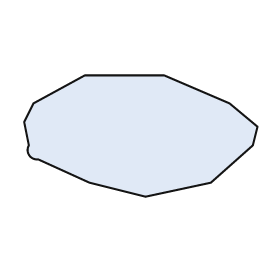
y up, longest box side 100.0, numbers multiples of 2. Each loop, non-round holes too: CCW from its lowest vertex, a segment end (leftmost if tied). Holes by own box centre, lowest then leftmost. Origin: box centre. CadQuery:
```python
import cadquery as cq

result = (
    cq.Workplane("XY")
    .moveTo(2.0, -26.0)
    .lineTo(30.0, -20.0)
    .lineTo(48.0, -4.0)
    .lineTo(50.0, 4.0)
    .lineTo(38.0, 14.0)
    .lineTo(10.0, 26.0)
    .lineTo(-24.0, 26.0)
    .lineTo(-46.0, 14.0)
    .lineTo(-50.0, 6.0)
    .lineTo(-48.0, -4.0)
    .threePointArc((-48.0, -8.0), (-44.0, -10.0))
    .lineTo(-22.0, -20.0)
    .close()
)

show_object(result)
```